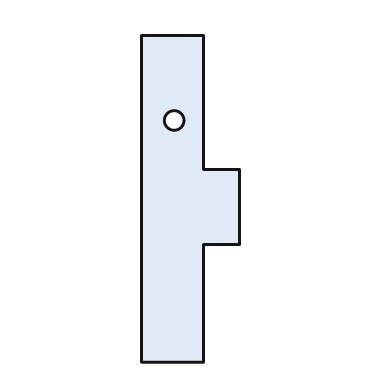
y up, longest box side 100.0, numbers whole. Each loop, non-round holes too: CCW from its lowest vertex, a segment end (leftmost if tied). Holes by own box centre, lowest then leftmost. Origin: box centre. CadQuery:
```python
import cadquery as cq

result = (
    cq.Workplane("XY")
    .moveTo(-15.0, -50.0)
    .lineTo(4.0, -50.0)
    .lineTo(4.0, -14.0)
    .lineTo(15.0, -14.0)
    .lineTo(15.0, 9.0)
    .lineTo(4.0, 9.0)
    .lineTo(4.0, 50.0)
    .lineTo(-15.0, 50.0)
    .close()
    .moveTo(-5.0, 24.0)
    .circle(3.0)
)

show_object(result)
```